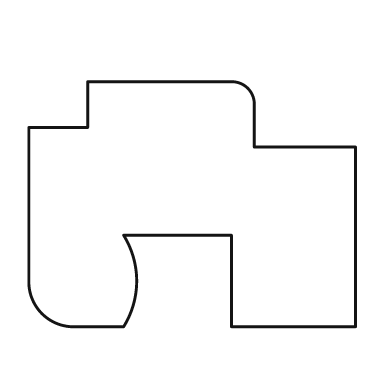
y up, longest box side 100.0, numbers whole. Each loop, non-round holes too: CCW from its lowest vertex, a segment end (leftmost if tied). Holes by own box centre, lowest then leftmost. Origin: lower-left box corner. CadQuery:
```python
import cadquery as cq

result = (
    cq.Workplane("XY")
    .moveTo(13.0, 0.0)
    .lineTo(29.0, 0.0)
    .threePointArc((33.0, 14.0), (29.0, 28.0))
    .lineTo(62.0, 28.0)
    .lineTo(62.0, 0.0)
    .lineTo(100.0, 0.0)
    .lineTo(100.0, 55.0)
    .lineTo(69.0, 55.0)
    .lineTo(69.0, 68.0)
    .threePointArc((67.0, 73.0), (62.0, 75.0))
    .lineTo(18.0, 75.0)
    .lineTo(18.0, 61.0)
    .lineTo(0.0, 61.0)
    .lineTo(0.0, 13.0)
    .threePointArc((4.0, 4.0), (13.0, 0.0))
    .close()
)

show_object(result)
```